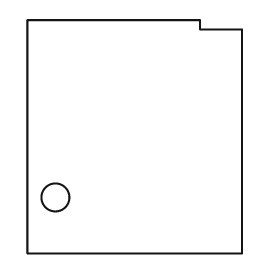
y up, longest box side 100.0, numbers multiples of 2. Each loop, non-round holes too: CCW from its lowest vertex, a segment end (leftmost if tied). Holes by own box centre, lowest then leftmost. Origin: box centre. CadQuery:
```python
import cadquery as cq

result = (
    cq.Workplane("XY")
    .moveTo(-46.0, -50.0)
    .lineTo(46.0, -50.0)
    .lineTo(46.0, 46.0)
    .lineTo(28.0, 46.0)
    .lineTo(28.0, 50.0)
    .lineTo(-46.0, 50.0)
    .close()
    .moveTo(-34.0, -26.0)
    .circle(6.0)
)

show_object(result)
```